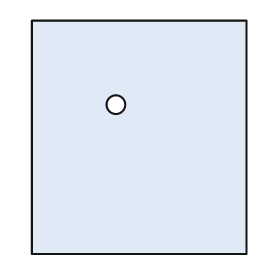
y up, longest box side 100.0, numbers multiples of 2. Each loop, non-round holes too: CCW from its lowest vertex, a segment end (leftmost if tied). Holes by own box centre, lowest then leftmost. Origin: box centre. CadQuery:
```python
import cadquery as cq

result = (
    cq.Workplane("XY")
    .moveTo(-46.0, -50.0)
    .lineTo(46.0, -50.0)
    .lineTo(46.0, 50.0)
    .lineTo(-46.0, 50.0)
    .close()
    .moveTo(-10.0, 14.0)
    .circle(4.0)
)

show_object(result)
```